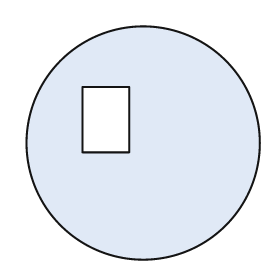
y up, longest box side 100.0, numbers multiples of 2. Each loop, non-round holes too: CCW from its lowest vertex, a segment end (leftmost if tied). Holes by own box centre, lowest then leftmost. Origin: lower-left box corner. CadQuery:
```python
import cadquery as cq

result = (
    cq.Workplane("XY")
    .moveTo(50.0, 50.0)
    .circle(50.0)
    .moveTo(24.0, 46.0)
    .lineTo(44.0, 46.0)
    .lineTo(44.0, 74.0)
    .lineTo(24.0, 74.0)
    .close()
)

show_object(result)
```